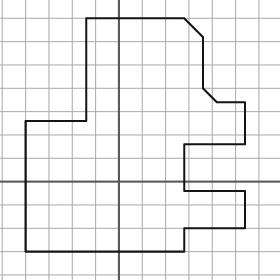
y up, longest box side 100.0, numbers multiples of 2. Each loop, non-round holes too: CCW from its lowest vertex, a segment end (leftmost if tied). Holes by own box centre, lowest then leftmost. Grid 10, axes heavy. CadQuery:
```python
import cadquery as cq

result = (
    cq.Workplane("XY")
    .moveTo(-40.0, -30.0)
    .lineTo(28.0, -30.0)
    .lineTo(28.0, -20.0)
    .lineTo(54.0, -20.0)
    .lineTo(54.0, -4.0)
    .lineTo(28.0, -4.0)
    .lineTo(28.0, 16.0)
    .lineTo(54.0, 16.0)
    .lineTo(54.0, 34.0)
    .lineTo(42.0, 34.0)
    .lineTo(36.0, 40.0)
    .lineTo(36.0, 62.0)
    .lineTo(28.0, 70.0)
    .lineTo(-14.0, 70.0)
    .lineTo(-14.0, 26.0)
    .lineTo(-40.0, 26.0)
    .close()
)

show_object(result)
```